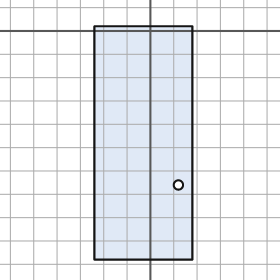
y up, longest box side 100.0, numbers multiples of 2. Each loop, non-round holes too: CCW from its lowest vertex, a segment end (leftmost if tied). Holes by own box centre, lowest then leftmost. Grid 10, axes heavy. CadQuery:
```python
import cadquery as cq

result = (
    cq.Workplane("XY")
    .moveTo(-24.0, -98.0)
    .lineTo(18.0, -98.0)
    .lineTo(18.0, 2.0)
    .lineTo(-24.0, 2.0)
    .close()
    .moveTo(12.0, -66.0)
    .circle(2.0)
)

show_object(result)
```